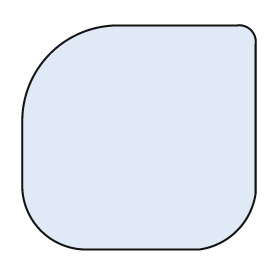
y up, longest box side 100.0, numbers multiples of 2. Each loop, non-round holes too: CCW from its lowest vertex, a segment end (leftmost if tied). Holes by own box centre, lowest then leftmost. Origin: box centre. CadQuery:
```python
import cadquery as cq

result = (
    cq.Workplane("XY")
    .moveTo(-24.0, -48.0)
    .lineTo(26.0, -48.0)
    .threePointArc((42.0, -40.0), (50.0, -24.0))
    .lineTo(50.0, 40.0)
    .threePointArc((48.0, 46.0), (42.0, 48.0))
    .lineTo(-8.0, 48.0)
    .threePointArc((-38.0, 36.0), (-50.0, 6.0))
    .lineTo(-50.0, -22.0)
    .threePointArc((-42.0, -40.0), (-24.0, -48.0))
    .close()
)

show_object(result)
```